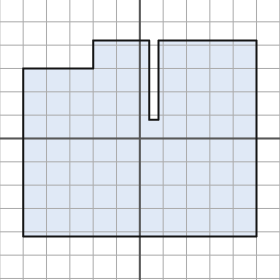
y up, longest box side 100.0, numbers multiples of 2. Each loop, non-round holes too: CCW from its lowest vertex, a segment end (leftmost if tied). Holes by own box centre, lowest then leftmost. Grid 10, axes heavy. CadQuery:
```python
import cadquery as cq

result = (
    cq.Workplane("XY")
    .moveTo(-50.0, -42.0)
    .lineTo(50.0, -42.0)
    .lineTo(50.0, 42.0)
    .lineTo(8.0, 42.0)
    .lineTo(8.0, 8.0)
    .lineTo(4.0, 8.0)
    .lineTo(4.0, 42.0)
    .lineTo(-20.0, 42.0)
    .lineTo(-20.0, 30.0)
    .lineTo(-50.0, 30.0)
    .close()
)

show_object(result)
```